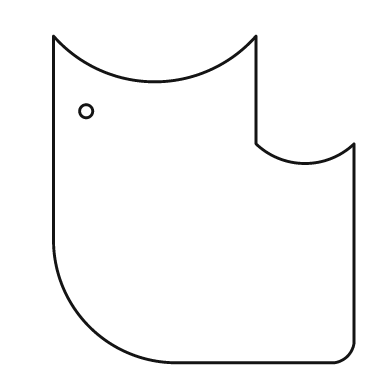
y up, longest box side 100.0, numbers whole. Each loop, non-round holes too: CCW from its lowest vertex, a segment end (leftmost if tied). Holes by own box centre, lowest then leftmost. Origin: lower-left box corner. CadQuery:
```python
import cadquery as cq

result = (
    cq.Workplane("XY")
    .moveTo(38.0, 0.0)
    .lineTo(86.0, 0.0)
    .threePointArc((90.0, 2.0), (92.0, 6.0))
    .lineTo(92.0, 67.0)
    .threePointArc((77.0, 61.0), (62.0, 67.0))
    .lineTo(62.0, 100.0)
    .threePointArc((31.0, 86.0), (0.0, 100.0))
    .lineTo(0.0, 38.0)
    .threePointArc((11.0, 11.0), (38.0, 0.0))
    .close()
    .moveTo(10.0, 77.0)
    .circle(2.0)
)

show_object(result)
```